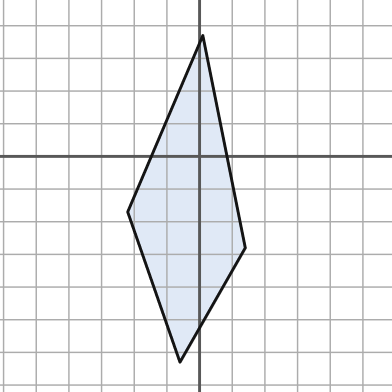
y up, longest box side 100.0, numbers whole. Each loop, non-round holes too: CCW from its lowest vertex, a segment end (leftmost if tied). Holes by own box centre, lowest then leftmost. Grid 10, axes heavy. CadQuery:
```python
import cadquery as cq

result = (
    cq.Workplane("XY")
    .moveTo(-6.0, -63.0)
    .lineTo(14.0, -28.0)
    .lineTo(1.0, 37.0)
    .lineTo(-22.0, -17.0)
    .close()
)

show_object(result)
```